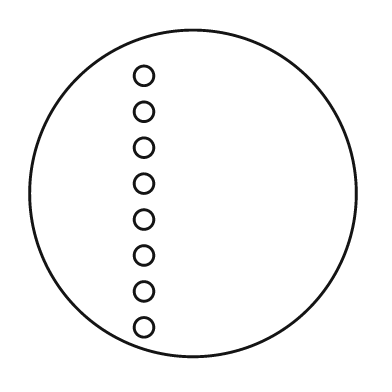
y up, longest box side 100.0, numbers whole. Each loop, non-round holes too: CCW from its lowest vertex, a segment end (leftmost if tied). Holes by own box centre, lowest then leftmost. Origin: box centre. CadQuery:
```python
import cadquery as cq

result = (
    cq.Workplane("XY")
    .moveTo(0.0, 0.0)
    .circle(50.0)
    .moveTo(-15.0, -41.0)
    .circle(3.0)
    .moveTo(-15.0, -30.0)
    .circle(3.0)
    .moveTo(-15.0, -19.0)
    .circle(3.0)
    .moveTo(-15.0, -8.0)
    .circle(3.0)
    .moveTo(-15.0, 3.0)
    .circle(3.0)
    .moveTo(-15.0, 14.0)
    .circle(3.0)
    .moveTo(-15.0, 25.0)
    .circle(3.0)
    .moveTo(-15.0, 36.0)
    .circle(3.0)
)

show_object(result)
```